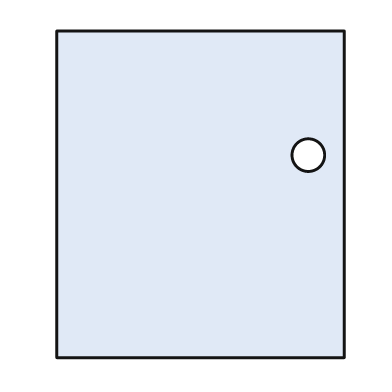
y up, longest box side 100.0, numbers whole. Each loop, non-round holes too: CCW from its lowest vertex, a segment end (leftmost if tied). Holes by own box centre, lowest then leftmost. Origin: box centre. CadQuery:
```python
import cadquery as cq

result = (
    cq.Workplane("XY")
    .moveTo(-44.0, -50.0)
    .lineTo(44.0, -50.0)
    .lineTo(44.0, 50.0)
    .lineTo(-44.0, 50.0)
    .close()
    .moveTo(33.0, 12.0)
    .circle(5.0)
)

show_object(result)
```